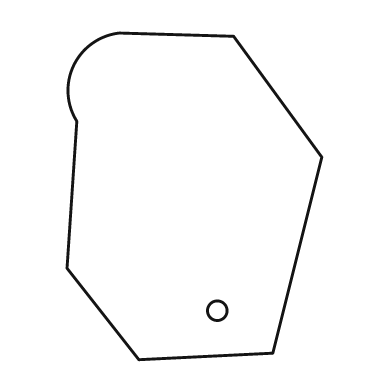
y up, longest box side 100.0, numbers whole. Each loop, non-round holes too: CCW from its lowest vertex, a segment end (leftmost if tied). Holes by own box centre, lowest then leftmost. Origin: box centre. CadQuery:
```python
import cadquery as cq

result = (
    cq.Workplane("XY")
    .moveTo(-17.0, -50.0)
    .lineTo(24.0, -48.0)
    .lineTo(39.0, 12.0)
    .lineTo(12.0, 49.0)
    .lineTo(-23.0, 50.0)
    .threePointArc((-37.0, 40.0), (-36.0, 23.0))
    .lineTo(-39.0, -22.0)
    .close()
    .moveTo(7.0, -35.0)
    .circle(3.0)
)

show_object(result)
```